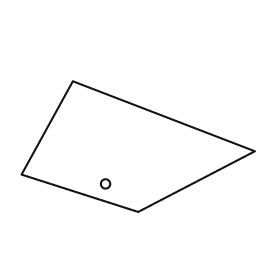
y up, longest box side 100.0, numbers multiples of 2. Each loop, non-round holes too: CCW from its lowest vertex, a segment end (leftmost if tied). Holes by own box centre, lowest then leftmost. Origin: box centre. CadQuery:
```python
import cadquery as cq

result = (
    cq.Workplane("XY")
    .moveTo(0.0, -28.0)
    .lineTo(50.0, -2.0)
    .lineTo(-28.0, 28.0)
    .lineTo(-50.0, -12.0)
    .close()
    .moveTo(-14.0, -16.0)
    .circle(2.0)
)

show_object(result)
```